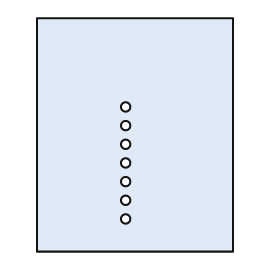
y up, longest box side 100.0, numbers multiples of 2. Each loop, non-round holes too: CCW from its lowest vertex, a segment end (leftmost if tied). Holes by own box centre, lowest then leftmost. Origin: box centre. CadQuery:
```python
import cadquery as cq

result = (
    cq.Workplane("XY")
    .moveTo(-42.0, -50.0)
    .lineTo(42.0, -50.0)
    .lineTo(42.0, 50.0)
    .lineTo(-42.0, 50.0)
    .close()
    .moveTo(-4.0, -36.0)
    .circle(2.0)
    .moveTo(-4.0, -28.0)
    .circle(2.0)
    .moveTo(-4.0, -20.0)
    .circle(2.0)
    .moveTo(-4.0, -12.0)
    .circle(2.0)
    .moveTo(-4.0, -4.0)
    .circle(2.0)
    .moveTo(-4.0, 4.0)
    .circle(2.0)
    .moveTo(-4.0, 12.0)
    .circle(2.0)
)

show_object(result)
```